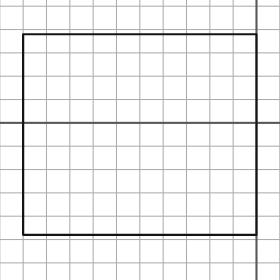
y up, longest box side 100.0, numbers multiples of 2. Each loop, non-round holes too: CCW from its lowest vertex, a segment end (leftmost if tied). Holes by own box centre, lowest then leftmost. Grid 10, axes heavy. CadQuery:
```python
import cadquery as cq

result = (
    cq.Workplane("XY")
    .moveTo(-100.0, -48.0)
    .lineTo(0.0, -48.0)
    .lineTo(0.0, 38.0)
    .lineTo(-100.0, 38.0)
    .close()
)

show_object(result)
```